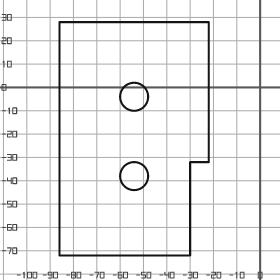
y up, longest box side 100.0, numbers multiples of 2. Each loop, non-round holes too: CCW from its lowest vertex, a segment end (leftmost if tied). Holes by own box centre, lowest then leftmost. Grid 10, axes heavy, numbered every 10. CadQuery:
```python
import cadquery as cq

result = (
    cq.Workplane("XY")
    .moveTo(-86.0, -72.0)
    .lineTo(-30.0, -72.0)
    .lineTo(-30.0, -32.0)
    .lineTo(-22.0, -32.0)
    .lineTo(-22.0, 28.0)
    .lineTo(-86.0, 28.0)
    .close()
    .moveTo(-54.0, -38.0)
    .circle(6.0)
    .moveTo(-54.0, -4.0)
    .circle(6.0)
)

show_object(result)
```